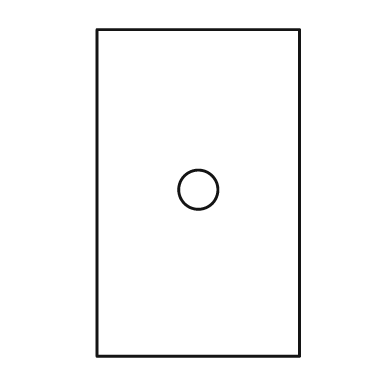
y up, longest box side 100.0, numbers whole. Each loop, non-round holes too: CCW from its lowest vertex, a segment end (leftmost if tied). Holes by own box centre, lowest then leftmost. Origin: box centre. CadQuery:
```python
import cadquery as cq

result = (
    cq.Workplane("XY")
    .moveTo(-31.0, -50.0)
    .lineTo(31.0, -50.0)
    .lineTo(31.0, 50.0)
    .lineTo(-31.0, 50.0)
    .close()
    .moveTo(0.0, 1.0)
    .circle(6.0)
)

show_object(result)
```